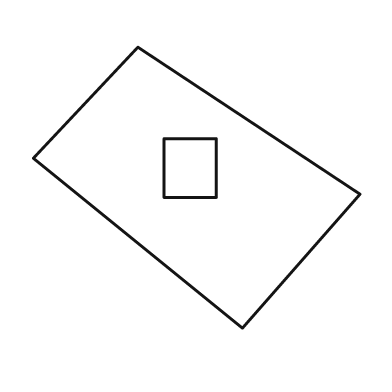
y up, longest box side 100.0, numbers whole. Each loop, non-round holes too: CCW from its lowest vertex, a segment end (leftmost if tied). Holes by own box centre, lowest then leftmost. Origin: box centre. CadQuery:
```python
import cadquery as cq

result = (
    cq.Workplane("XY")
    .moveTo(14.0, -43.0)
    .lineTo(50.0, -2.0)
    .lineTo(-18.0, 43.0)
    .lineTo(-50.0, 9.0)
    .close()
    .moveTo(-10.0, -3.0)
    .lineTo(6.0, -3.0)
    .lineTo(6.0, 15.0)
    .lineTo(-10.0, 15.0)
    .close()
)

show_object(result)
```